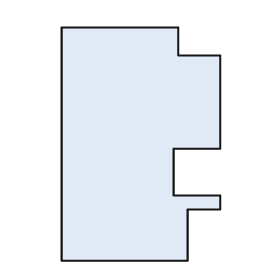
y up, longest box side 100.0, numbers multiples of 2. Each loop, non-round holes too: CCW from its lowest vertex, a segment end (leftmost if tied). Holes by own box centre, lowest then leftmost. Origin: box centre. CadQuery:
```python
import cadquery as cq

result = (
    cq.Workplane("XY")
    .moveTo(-34.0, -50.0)
    .lineTo(20.0, -50.0)
    .lineTo(20.0, -28.0)
    .lineTo(34.0, -28.0)
    .lineTo(34.0, -22.0)
    .lineTo(14.0, -22.0)
    .lineTo(14.0, -2.0)
    .lineTo(34.0, -2.0)
    .lineTo(34.0, 38.0)
    .lineTo(16.0, 38.0)
    .lineTo(16.0, 50.0)
    .lineTo(-34.0, 50.0)
    .close()
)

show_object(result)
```